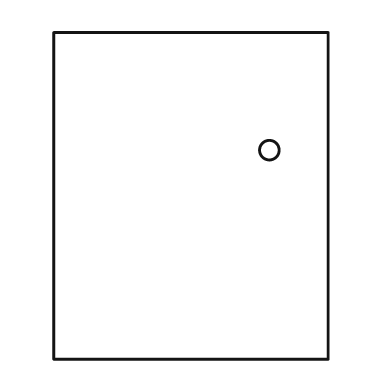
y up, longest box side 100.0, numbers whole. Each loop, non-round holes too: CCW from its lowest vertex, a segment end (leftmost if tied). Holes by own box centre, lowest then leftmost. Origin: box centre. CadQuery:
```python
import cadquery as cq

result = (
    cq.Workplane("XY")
    .moveTo(-42.0, -50.0)
    .lineTo(42.0, -50.0)
    .lineTo(42.0, 50.0)
    .lineTo(-42.0, 50.0)
    .close()
    .moveTo(24.0, 14.0)
    .circle(3.0)
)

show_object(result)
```